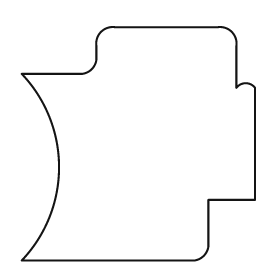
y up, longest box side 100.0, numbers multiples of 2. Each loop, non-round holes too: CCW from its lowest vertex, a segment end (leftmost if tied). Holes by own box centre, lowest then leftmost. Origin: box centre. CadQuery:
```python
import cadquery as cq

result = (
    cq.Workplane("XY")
    .moveTo(-50.0, -50.0)
    .lineTo(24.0, -50.0)
    .threePointArc((28.0, -48.0), (30.0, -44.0))
    .lineTo(30.0, -24.0)
    .lineTo(50.0, -24.0)
    .lineTo(50.0, 24.0)
    .threePointArc((46.0, 26.0), (42.0, 24.0))
    .lineTo(42.0, 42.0)
    .threePointArc((40.0, 48.0), (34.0, 50.0))
    .lineTo(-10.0, 50.0)
    .threePointArc((-16.0, 48.0), (-18.0, 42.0))
    .lineTo(-18.0, 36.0)
    .threePointArc((-20.0, 32.0), (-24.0, 30.0))
    .lineTo(-50.0, 30.0)
    .threePointArc((-34.0, -10.0), (-50.0, -50.0))
    .close()
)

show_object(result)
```